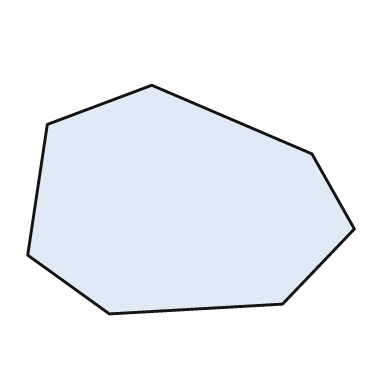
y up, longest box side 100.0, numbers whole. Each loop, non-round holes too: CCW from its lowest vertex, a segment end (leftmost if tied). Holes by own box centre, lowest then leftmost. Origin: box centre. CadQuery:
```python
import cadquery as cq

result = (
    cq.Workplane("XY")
    .moveTo(-25.0, -35.0)
    .lineTo(28.0, -32.0)
    .lineTo(50.0, -9.0)
    .lineTo(37.0, 14.0)
    .lineTo(-12.0, 35.0)
    .lineTo(-44.0, 23.0)
    .lineTo(-50.0, -17.0)
    .close()
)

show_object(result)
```